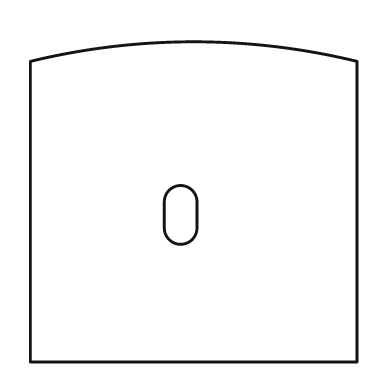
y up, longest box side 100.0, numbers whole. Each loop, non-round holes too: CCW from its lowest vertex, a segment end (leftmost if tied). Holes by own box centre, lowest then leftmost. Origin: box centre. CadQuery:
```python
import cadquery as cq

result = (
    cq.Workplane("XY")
    .moveTo(-50.0, -49.0)
    .lineTo(50.0, -49.0)
    .lineTo(50.0, 43.0)
    .threePointArc((0.0, 49.0), (-50.0, 43.0))
    .close()
    .moveTo(-9.0, -8.0)
    .threePointArc((-4.0, -13.0), (1.0, -8.0))
    .lineTo(1.0, 0.0)
    .threePointArc((-4.0, 5.0), (-9.0, 0.0))
    .close()
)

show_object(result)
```